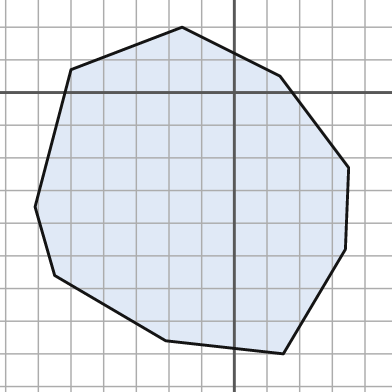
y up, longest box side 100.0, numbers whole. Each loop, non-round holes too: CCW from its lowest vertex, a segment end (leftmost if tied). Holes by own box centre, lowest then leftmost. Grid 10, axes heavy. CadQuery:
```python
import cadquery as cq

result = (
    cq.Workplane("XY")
    .moveTo(15.0, -80.0)
    .lineTo(34.0, -48.0)
    .lineTo(35.0, -23.0)
    .lineTo(14.0, 5.0)
    .lineTo(-16.0, 20.0)
    .lineTo(-50.0, 7.0)
    .lineTo(-61.0, -35.0)
    .lineTo(-55.0, -56.0)
    .lineTo(-21.0, -76.0)
    .close()
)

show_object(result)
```